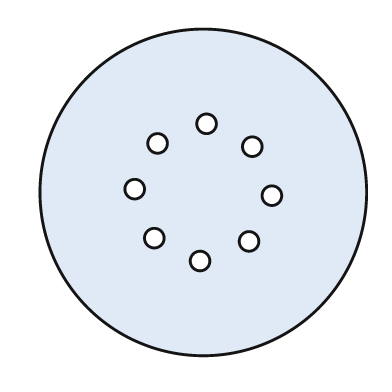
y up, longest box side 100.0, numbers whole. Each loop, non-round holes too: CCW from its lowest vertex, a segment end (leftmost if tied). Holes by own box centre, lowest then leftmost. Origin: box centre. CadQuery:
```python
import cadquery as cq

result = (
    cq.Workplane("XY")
    .moveTo(0.0, 0.0)
    .circle(50.0)
    .moveTo(-1.0, -21.0)
    .circle(3.0)
    .moveTo(14.0, -15.0)
    .circle(3.0)
    .moveTo(-15.0, -14.0)
    .circle(3.0)
    .moveTo(21.0, -1.0)
    .circle(3.0)
    .moveTo(-21.0, 1.0)
    .circle(3.0)
    .moveTo(15.0, 14.0)
    .circle(3.0)
    .moveTo(-14.0, 15.0)
    .circle(3.0)
    .moveTo(1.0, 21.0)
    .circle(3.0)
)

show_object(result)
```